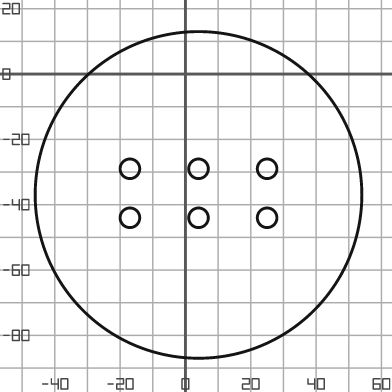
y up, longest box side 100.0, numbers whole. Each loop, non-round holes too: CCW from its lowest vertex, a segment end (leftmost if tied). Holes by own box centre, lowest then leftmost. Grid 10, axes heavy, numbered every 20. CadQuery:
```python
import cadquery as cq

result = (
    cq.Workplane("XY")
    .moveTo(4.0, -37.0)
    .circle(50.0)
    .moveTo(-17.0, -44.0)
    .circle(3.0)
    .moveTo(4.0, -44.0)
    .circle(3.0)
    .moveTo(25.0, -44.0)
    .circle(3.0)
    .moveTo(-17.0, -29.0)
    .circle(3.0)
    .moveTo(4.0, -29.0)
    .circle(3.0)
    .moveTo(25.0, -29.0)
    .circle(3.0)
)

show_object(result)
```